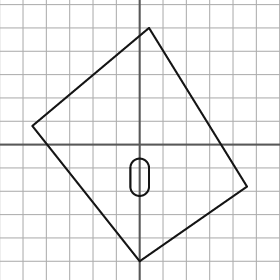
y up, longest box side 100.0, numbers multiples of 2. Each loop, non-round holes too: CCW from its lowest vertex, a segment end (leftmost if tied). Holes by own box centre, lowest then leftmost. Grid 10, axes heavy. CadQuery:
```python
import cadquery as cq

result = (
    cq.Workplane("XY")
    .moveTo(0.0, -50.0)
    .lineTo(46.0, -18.0)
    .lineTo(4.0, 50.0)
    .lineTo(-46.0, 8.0)
    .close()
    .moveTo(-4.0, -18.0)
    .threePointArc((0.0, -22.0), (4.0, -18.0))
    .lineTo(4.0, -10.0)
    .threePointArc((0.0, -6.0), (-4.0, -10.0))
    .close()
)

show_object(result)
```